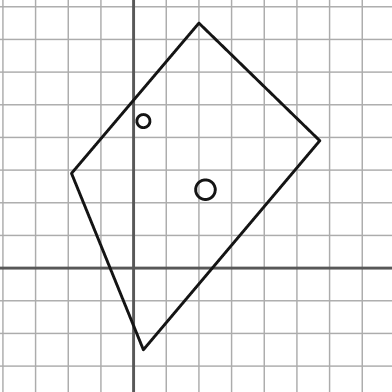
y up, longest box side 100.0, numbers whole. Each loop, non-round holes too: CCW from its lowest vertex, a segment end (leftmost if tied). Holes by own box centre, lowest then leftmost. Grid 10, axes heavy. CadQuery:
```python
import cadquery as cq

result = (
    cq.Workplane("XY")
    .moveTo(3.0, -25.0)
    .lineTo(57.0, 39.0)
    .lineTo(20.0, 75.0)
    .lineTo(-19.0, 29.0)
    .close()
    .moveTo(22.0, 24.0)
    .circle(3.0)
    .moveTo(3.0, 45.0)
    .circle(2.0)
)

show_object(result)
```